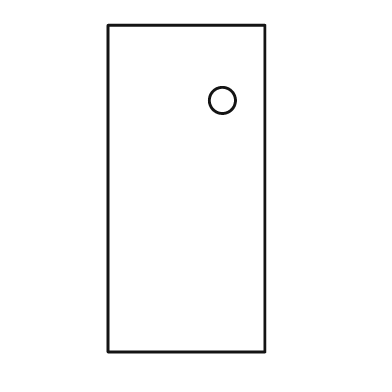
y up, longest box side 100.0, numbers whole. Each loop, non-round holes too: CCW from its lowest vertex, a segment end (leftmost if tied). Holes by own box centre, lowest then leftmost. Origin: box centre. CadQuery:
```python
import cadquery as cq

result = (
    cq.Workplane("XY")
    .moveTo(-24.0, -50.0)
    .lineTo(24.0, -50.0)
    .lineTo(24.0, 50.0)
    .lineTo(-24.0, 50.0)
    .close()
    .moveTo(11.0, 27.0)
    .circle(4.0)
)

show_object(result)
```